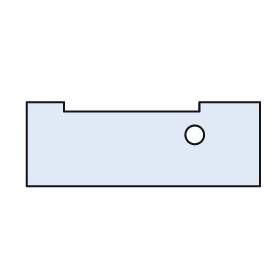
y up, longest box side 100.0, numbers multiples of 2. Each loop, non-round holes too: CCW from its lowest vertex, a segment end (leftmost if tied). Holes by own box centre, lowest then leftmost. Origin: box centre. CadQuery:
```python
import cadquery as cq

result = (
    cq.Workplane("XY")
    .moveTo(-50.0, -18.0)
    .lineTo(50.0, -18.0)
    .lineTo(50.0, 18.0)
    .lineTo(24.0, 18.0)
    .lineTo(24.0, 14.0)
    .lineTo(-34.0, 14.0)
    .lineTo(-34.0, 18.0)
    .lineTo(-50.0, 18.0)
    .close()
    .moveTo(22.0, 4.0)
    .circle(4.0)
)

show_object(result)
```